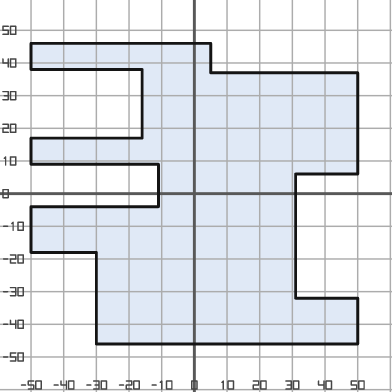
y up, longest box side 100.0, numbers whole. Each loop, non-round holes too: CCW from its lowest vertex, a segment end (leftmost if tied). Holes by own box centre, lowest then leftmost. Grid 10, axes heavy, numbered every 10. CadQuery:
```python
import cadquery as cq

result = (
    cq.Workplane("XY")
    .moveTo(-30.0, -46.0)
    .lineTo(50.0, -46.0)
    .lineTo(50.0, -32.0)
    .lineTo(31.0, -32.0)
    .lineTo(31.0, 6.0)
    .lineTo(50.0, 6.0)
    .lineTo(50.0, 37.0)
    .lineTo(5.0, 37.0)
    .lineTo(5.0, 46.0)
    .lineTo(-50.0, 46.0)
    .lineTo(-50.0, 38.0)
    .lineTo(-16.0, 38.0)
    .lineTo(-16.0, 17.0)
    .lineTo(-50.0, 17.0)
    .lineTo(-50.0, 9.0)
    .lineTo(-11.0, 9.0)
    .lineTo(-11.0, -4.0)
    .lineTo(-50.0, -4.0)
    .lineTo(-50.0, -18.0)
    .lineTo(-30.0, -18.0)
    .close()
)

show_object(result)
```